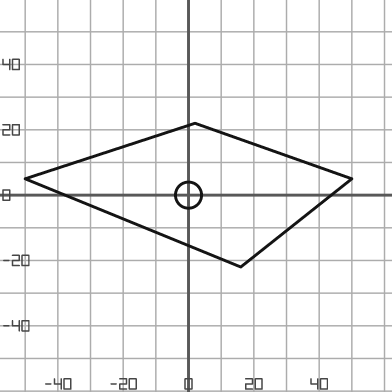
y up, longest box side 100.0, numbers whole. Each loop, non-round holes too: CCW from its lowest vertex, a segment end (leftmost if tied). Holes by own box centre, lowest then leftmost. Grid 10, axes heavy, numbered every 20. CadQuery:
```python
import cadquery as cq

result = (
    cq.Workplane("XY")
    .moveTo(16.0, -22.0)
    .lineTo(50.0, 5.0)
    .lineTo(2.0, 22.0)
    .lineTo(-50.0, 5.0)
    .close()
    .moveTo(0.0, 0.0)
    .circle(4.0)
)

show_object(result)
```